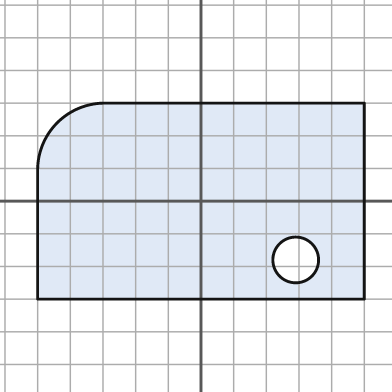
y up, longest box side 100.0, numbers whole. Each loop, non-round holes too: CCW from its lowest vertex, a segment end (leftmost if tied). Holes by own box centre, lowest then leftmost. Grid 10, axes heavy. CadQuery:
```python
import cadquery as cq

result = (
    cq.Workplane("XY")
    .moveTo(-50.0, -30.0)
    .lineTo(50.0, -30.0)
    .lineTo(50.0, 30.0)
    .lineTo(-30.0, 30.0)
    .threePointArc((-44.0, 24.0), (-50.0, 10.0))
    .close()
    .moveTo(29.0, -18.0)
    .circle(7.0)
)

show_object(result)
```